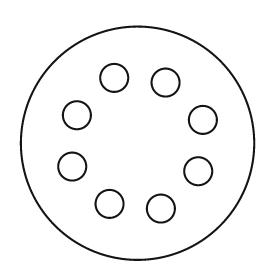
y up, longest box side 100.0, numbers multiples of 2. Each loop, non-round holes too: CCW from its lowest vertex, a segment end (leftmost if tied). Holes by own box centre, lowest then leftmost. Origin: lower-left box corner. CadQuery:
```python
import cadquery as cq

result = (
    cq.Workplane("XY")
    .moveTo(50.0, 50.0)
    .circle(50.0)
    .moveTo(60.0, 22.0)
    .circle(6.0)
    .moveTo(38.0, 24.0)
    .circle(6.0)
    .moveTo(76.0, 38.0)
    .circle(6.0)
    .moveTo(22.0, 40.0)
    .circle(6.0)
    .moveTo(78.0, 60.0)
    .circle(6.0)
    .moveTo(24.0, 62.0)
    .circle(6.0)
    .moveTo(62.0, 76.0)
    .circle(6.0)
    .moveTo(40.0, 78.0)
    .circle(6.0)
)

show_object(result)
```